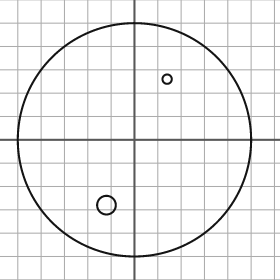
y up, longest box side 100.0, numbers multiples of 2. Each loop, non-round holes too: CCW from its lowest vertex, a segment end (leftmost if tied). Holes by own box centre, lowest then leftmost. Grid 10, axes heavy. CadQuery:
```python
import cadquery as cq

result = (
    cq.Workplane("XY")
    .moveTo(0.0, 0.0)
    .circle(50.0)
    .moveTo(-12.0, -28.0)
    .circle(4.0)
    .moveTo(14.0, 26.0)
    .circle(2.0)
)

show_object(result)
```